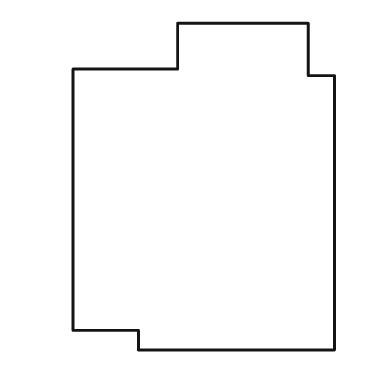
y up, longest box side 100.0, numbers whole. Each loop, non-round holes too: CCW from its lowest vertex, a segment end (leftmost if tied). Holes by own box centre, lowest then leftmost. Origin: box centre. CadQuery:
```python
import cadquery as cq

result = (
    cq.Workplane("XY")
    .moveTo(-20.0, -50.0)
    .lineTo(40.0, -50.0)
    .lineTo(40.0, 34.0)
    .lineTo(32.0, 34.0)
    .lineTo(32.0, 50.0)
    .lineTo(-8.0, 50.0)
    .lineTo(-8.0, 36.0)
    .lineTo(-40.0, 36.0)
    .lineTo(-40.0, -44.0)
    .lineTo(-20.0, -44.0)
    .close()
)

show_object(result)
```